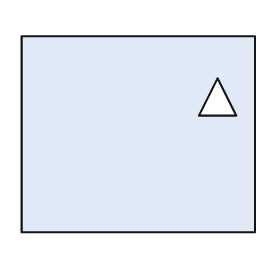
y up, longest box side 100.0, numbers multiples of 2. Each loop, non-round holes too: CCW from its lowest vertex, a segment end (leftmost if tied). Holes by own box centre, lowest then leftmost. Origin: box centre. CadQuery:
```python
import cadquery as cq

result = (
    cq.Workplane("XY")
    .moveTo(-50.0, -42.0)
    .lineTo(50.0, -42.0)
    .lineTo(50.0, 42.0)
    .lineTo(-50.0, 42.0)
    .close()
    .moveTo(26.0, 8.0)
    .lineTo(42.0, 8.0)
    .lineTo(34.0, 24.0)
    .close()
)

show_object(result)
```